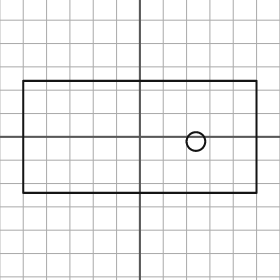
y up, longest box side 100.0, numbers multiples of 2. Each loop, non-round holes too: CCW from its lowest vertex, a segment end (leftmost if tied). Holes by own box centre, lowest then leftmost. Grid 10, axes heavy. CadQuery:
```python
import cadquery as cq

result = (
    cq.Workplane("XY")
    .moveTo(-50.0, -24.0)
    .lineTo(50.0, -24.0)
    .lineTo(50.0, 24.0)
    .lineTo(-50.0, 24.0)
    .close()
    .moveTo(24.0, -2.0)
    .circle(4.0)
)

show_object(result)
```